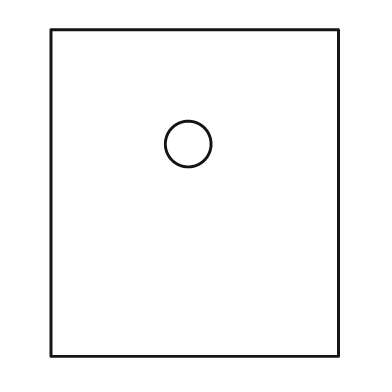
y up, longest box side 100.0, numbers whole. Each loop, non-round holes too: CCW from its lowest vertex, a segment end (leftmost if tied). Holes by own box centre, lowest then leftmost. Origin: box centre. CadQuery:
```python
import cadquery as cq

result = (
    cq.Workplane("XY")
    .moveTo(-44.0, -50.0)
    .lineTo(44.0, -50.0)
    .lineTo(44.0, 50.0)
    .lineTo(-44.0, 50.0)
    .close()
    .moveTo(-2.0, 15.0)
    .circle(7.0)
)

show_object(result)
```